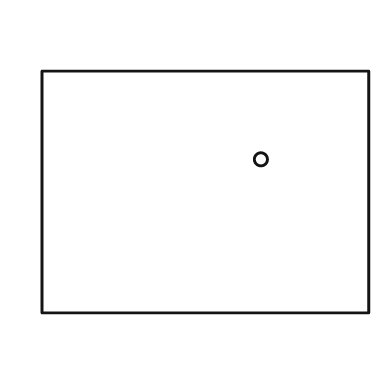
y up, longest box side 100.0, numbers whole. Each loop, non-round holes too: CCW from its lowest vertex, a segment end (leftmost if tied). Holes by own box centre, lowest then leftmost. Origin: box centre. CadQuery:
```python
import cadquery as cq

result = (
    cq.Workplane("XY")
    .moveTo(-50.0, -37.0)
    .lineTo(50.0, -37.0)
    .lineTo(50.0, 37.0)
    .lineTo(-50.0, 37.0)
    .close()
    .moveTo(17.0, 10.0)
    .circle(2.0)
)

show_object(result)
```